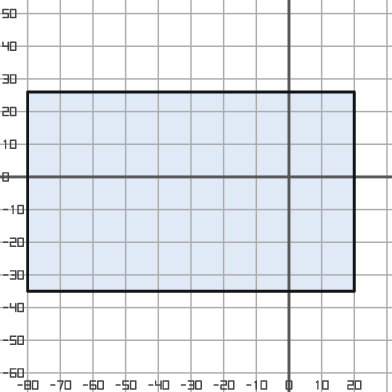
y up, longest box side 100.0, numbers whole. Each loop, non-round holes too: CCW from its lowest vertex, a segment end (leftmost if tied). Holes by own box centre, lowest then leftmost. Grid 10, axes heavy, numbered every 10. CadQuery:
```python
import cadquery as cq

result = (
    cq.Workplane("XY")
    .moveTo(-80.0, -35.0)
    .lineTo(20.0, -35.0)
    .lineTo(20.0, 26.0)
    .lineTo(-80.0, 26.0)
    .close()
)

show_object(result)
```